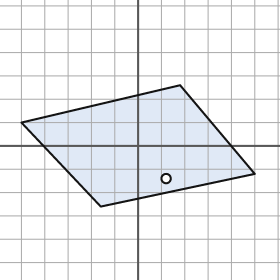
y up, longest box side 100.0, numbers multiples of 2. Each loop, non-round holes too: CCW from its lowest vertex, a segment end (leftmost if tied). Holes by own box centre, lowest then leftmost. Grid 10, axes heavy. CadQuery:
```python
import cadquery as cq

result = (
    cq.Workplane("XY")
    .moveTo(-16.0, -26.0)
    .lineTo(50.0, -12.0)
    .lineTo(18.0, 26.0)
    .lineTo(-50.0, 10.0)
    .close()
    .moveTo(12.0, -14.0)
    .circle(2.0)
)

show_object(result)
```